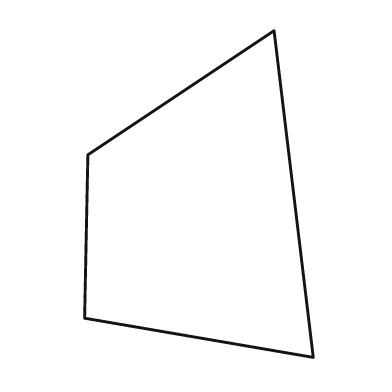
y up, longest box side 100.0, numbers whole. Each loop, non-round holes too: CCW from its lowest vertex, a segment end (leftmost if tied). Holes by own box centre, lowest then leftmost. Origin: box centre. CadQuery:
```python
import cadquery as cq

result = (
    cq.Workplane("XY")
    .moveTo(35.0, -50.0)
    .lineTo(23.0, 50.0)
    .lineTo(-34.0, 12.0)
    .lineTo(-35.0, -38.0)
    .close()
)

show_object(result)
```